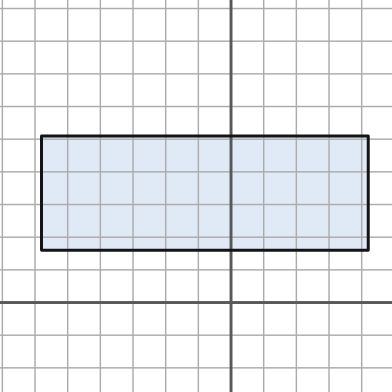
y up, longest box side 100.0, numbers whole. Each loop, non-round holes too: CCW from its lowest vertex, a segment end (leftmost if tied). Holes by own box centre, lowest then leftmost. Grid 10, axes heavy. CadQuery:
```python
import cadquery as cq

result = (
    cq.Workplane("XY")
    .moveTo(-58.0, 16.0)
    .lineTo(42.0, 16.0)
    .lineTo(42.0, 51.0)
    .lineTo(-58.0, 51.0)
    .close()
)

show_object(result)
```